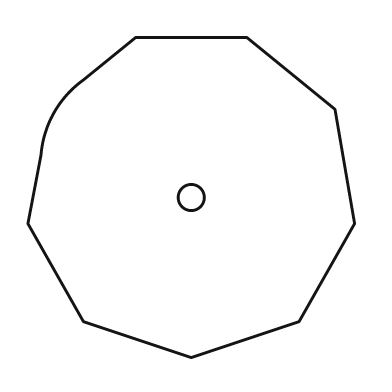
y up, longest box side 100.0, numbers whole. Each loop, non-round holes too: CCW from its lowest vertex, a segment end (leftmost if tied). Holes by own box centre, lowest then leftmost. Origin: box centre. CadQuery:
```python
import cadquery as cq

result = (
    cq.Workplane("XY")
    .moveTo(0.0, -49.0)
    .lineTo(33.0, -38.0)
    .lineTo(50.0, -8.0)
    .lineTo(44.0, 27.0)
    .lineTo(17.0, 49.0)
    .lineTo(-17.0, 49.0)
    .lineTo(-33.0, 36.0)
    .threePointArc((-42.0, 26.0), (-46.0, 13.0))
    .lineTo(-50.0, -8.0)
    .lineTo(-33.0, -38.0)
    .close()
    .moveTo(0.0, 0.0)
    .circle(4.0)
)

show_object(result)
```